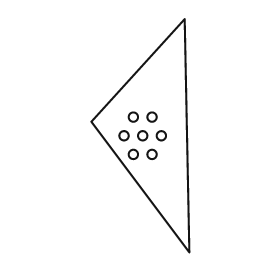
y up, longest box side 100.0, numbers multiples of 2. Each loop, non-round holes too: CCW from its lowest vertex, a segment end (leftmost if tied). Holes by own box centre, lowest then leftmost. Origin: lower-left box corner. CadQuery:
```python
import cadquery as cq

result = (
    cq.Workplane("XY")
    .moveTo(42.0, 0.0)
    .lineTo(40.0, 100.0)
    .lineTo(0.0, 56.0)
    .close()
    .moveTo(18.0, 42.0)
    .circle(2.0)
    .moveTo(26.0, 42.0)
    .circle(2.0)
    .moveTo(14.0, 50.0)
    .circle(2.0)
    .moveTo(22.0, 50.0)
    .circle(2.0)
    .moveTo(30.0, 50.0)
    .circle(2.0)
    .moveTo(18.0, 58.0)
    .circle(2.0)
    .moveTo(26.0, 58.0)
    .circle(2.0)
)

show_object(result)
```